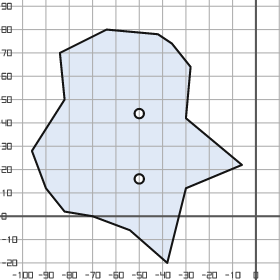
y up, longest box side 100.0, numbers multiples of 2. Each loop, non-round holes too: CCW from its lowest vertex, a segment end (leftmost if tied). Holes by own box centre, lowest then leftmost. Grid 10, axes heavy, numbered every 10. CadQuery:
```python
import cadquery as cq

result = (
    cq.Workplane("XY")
    .moveTo(-38.0, -20.0)
    .lineTo(-30.0, 12.0)
    .lineTo(-6.0, 22.0)
    .lineTo(-30.0, 42.0)
    .lineTo(-28.0, 64.0)
    .lineTo(-36.0, 74.0)
    .lineTo(-42.0, 78.0)
    .lineTo(-64.0, 80.0)
    .lineTo(-84.0, 70.0)
    .lineTo(-82.0, 50.0)
    .lineTo(-96.0, 28.0)
    .lineTo(-90.0, 12.0)
    .lineTo(-82.0, 2.0)
    .lineTo(-70.0, 0.0)
    .lineTo(-54.0, -6.0)
    .close()
    .moveTo(-50.0, 16.0)
    .circle(2.0)
    .moveTo(-50.0, 44.0)
    .circle(2.0)
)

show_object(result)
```